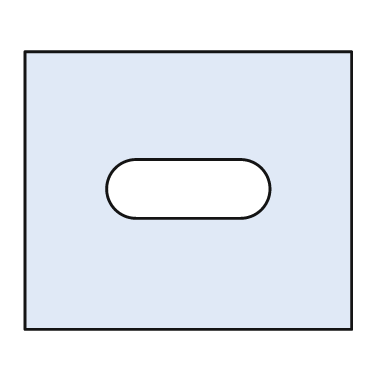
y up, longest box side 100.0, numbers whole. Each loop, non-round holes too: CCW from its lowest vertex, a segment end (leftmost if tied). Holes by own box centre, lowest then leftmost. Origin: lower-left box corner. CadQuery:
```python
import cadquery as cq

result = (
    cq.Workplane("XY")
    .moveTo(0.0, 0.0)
    .lineTo(100.0, 0.0)
    .lineTo(100.0, 85.0)
    .lineTo(0.0, 85.0)
    .close()
    .moveTo(34.0, 34.0)
    .lineTo(66.0, 34.0)
    .threePointArc((75.0, 43.0), (66.0, 52.0))
    .lineTo(34.0, 52.0)
    .threePointArc((25.0, 43.0), (34.0, 34.0))
    .close()
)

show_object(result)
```